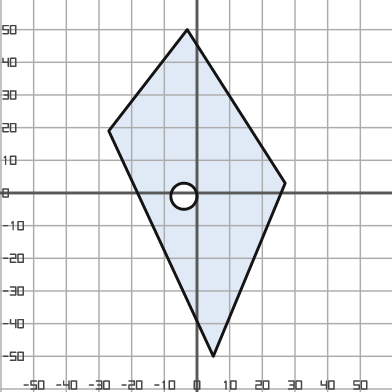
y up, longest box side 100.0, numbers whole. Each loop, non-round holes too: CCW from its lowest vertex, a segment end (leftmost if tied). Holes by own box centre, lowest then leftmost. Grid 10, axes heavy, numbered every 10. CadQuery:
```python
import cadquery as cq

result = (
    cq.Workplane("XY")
    .moveTo(5.0, -50.0)
    .lineTo(27.0, 3.0)
    .lineTo(-3.0, 50.0)
    .lineTo(-27.0, 19.0)
    .close()
    .moveTo(-4.0, -1.0)
    .circle(4.0)
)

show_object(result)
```